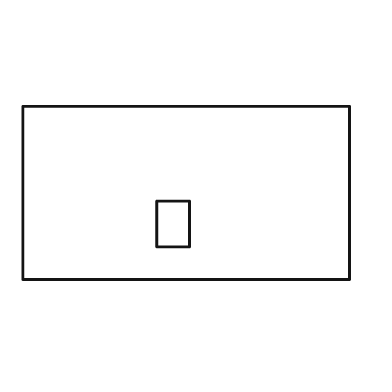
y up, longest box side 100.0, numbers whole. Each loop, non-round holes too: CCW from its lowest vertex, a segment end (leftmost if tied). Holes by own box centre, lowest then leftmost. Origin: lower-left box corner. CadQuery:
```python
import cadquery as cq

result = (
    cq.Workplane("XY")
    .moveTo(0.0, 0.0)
    .lineTo(100.0, 0.0)
    .lineTo(100.0, 53.0)
    .lineTo(0.0, 53.0)
    .close()
    .moveTo(41.0, 10.0)
    .lineTo(51.0, 10.0)
    .lineTo(51.0, 24.0)
    .lineTo(41.0, 24.0)
    .close()
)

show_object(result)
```